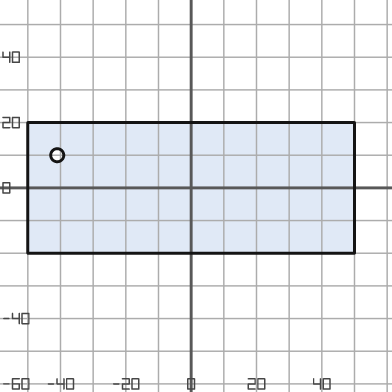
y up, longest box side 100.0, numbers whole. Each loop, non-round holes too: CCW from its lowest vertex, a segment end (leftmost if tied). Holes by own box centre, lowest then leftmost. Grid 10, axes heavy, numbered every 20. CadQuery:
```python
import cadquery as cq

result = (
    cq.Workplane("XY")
    .moveTo(-50.0, -20.0)
    .lineTo(50.0, -20.0)
    .lineTo(50.0, 20.0)
    .lineTo(-50.0, 20.0)
    .close()
    .moveTo(-41.0, 10.0)
    .circle(2.0)
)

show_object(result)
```